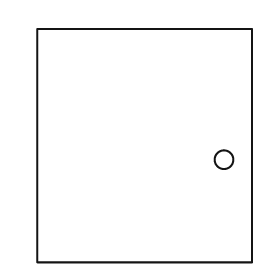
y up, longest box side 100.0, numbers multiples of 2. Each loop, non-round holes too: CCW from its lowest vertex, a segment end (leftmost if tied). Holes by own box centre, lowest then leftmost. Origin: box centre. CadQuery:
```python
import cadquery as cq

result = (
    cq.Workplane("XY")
    .moveTo(-46.0, -50.0)
    .lineTo(46.0, -50.0)
    .lineTo(46.0, 50.0)
    .lineTo(-46.0, 50.0)
    .close()
    .moveTo(34.0, -6.0)
    .circle(4.0)
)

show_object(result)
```